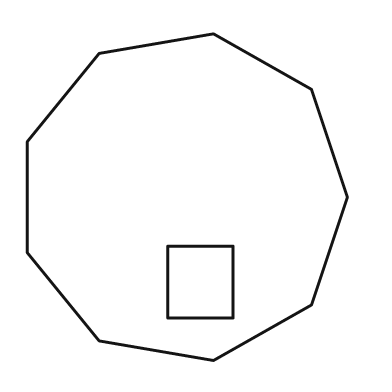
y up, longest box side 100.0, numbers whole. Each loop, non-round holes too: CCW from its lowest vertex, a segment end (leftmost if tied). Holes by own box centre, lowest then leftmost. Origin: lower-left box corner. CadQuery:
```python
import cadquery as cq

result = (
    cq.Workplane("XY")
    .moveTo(57.0, 0.0)
    .lineTo(87.0, 17.0)
    .lineTo(98.0, 50.0)
    .lineTo(87.0, 83.0)
    .lineTo(57.0, 100.0)
    .lineTo(22.0, 94.0)
    .lineTo(0.0, 67.0)
    .lineTo(0.0, 33.0)
    .lineTo(22.0, 6.0)
    .close()
    .moveTo(43.0, 13.0)
    .lineTo(63.0, 13.0)
    .lineTo(63.0, 35.0)
    .lineTo(43.0, 35.0)
    .close()
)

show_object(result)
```